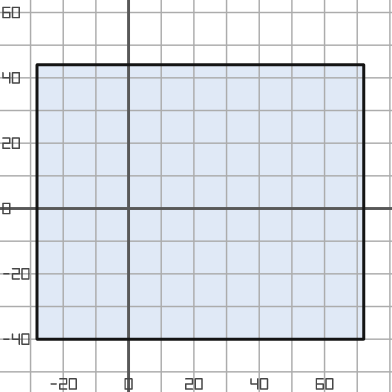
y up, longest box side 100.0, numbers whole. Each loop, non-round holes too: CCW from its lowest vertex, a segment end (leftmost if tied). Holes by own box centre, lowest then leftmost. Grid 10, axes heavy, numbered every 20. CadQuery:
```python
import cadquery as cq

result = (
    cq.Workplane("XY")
    .moveTo(-28.0, -40.0)
    .lineTo(72.0, -40.0)
    .lineTo(72.0, 44.0)
    .lineTo(-28.0, 44.0)
    .close()
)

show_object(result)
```